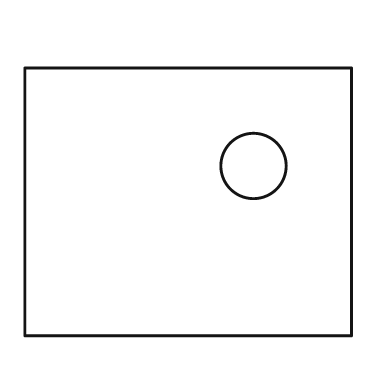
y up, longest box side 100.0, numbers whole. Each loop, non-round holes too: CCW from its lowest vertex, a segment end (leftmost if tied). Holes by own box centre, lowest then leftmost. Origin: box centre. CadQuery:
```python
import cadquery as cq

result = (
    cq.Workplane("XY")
    .moveTo(-50.0, -41.0)
    .lineTo(50.0, -41.0)
    .lineTo(50.0, 41.0)
    .lineTo(-50.0, 41.0)
    .close()
    .moveTo(20.0, 11.0)
    .circle(10.0)
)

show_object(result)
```